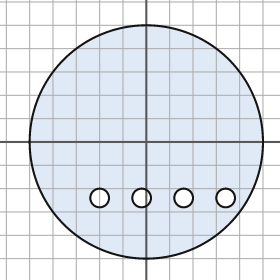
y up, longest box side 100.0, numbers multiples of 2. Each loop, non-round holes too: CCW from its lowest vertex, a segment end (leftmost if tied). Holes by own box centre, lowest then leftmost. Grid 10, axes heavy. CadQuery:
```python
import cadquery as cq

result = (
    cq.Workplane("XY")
    .moveTo(0.0, 0.0)
    .circle(50.0)
    .moveTo(-20.0, -24.0)
    .circle(4.0)
    .moveTo(-2.0, -24.0)
    .circle(4.0)
    .moveTo(16.0, -24.0)
    .circle(4.0)
    .moveTo(34.0, -24.0)
    .circle(4.0)
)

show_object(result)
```